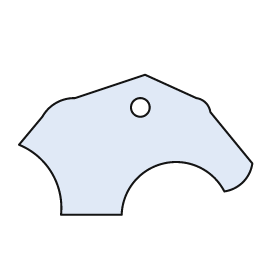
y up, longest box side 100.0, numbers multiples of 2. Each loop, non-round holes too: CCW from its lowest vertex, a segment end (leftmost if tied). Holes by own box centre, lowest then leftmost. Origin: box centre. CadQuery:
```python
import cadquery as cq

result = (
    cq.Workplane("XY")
    .moveTo(-32.0, -30.0)
    .lineTo(-6.0, -30.0)
    .threePointArc((12.0, -8.0), (38.0, -20.0))
    .threePointArc((46.0, -16.0), (50.0, -8.0))
    .lineTo(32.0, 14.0)
    .threePointArc((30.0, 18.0), (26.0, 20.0))
    .lineTo(4.0, 30.0)
    .lineTo(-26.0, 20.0)
    .threePointArc((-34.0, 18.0), (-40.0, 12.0))
    .lineTo(-50.0, 0.0)
    .threePointArc((-36.0, -12.0), (-32.0, -30.0))
    .close()
    .moveTo(2.0, 16.0)
    .circle(4.0)
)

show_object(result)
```